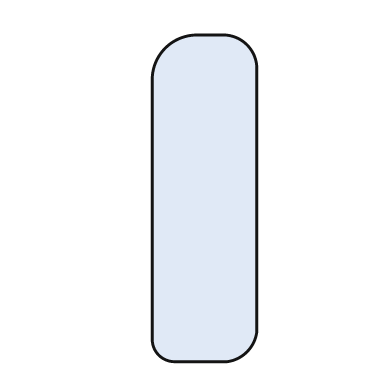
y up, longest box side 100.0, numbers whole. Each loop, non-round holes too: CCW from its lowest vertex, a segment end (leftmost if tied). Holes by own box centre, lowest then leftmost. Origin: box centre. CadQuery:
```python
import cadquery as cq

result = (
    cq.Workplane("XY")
    .moveTo(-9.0, -50.0)
    .lineTo(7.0, -50.0)
    .threePointArc((13.0, -47.0), (16.0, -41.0))
    .lineTo(16.0, 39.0)
    .threePointArc((13.0, 47.0), (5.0, 50.0))
    .lineTo(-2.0, 50.0)
    .threePointArc((-12.0, 46.0), (-16.0, 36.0))
    .lineTo(-16.0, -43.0)
    .threePointArc((-14.0, -48.0), (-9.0, -50.0))
    .close()
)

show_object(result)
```